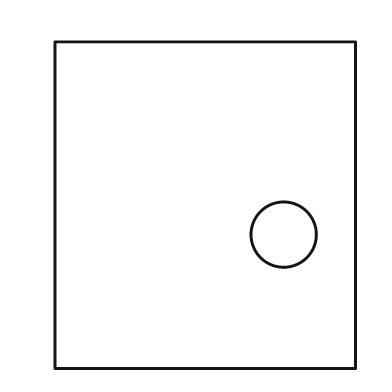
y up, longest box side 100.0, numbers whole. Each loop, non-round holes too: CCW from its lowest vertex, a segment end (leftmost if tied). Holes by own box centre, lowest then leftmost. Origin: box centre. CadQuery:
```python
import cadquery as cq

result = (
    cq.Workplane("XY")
    .moveTo(-46.0, -50.0)
    .lineTo(46.0, -50.0)
    .lineTo(46.0, 50.0)
    .lineTo(-46.0, 50.0)
    .close()
    .moveTo(24.0, -9.0)
    .circle(10.0)
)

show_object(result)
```